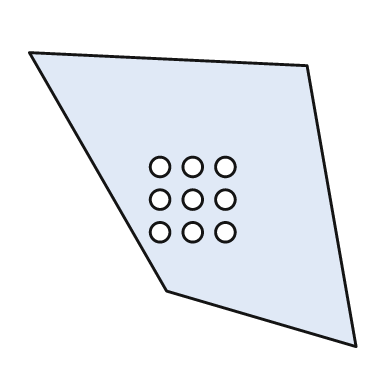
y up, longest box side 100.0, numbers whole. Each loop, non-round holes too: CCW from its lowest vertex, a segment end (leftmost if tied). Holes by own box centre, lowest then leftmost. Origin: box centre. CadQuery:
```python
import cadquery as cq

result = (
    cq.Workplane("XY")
    .moveTo(50.0, -45.0)
    .lineTo(35.0, 41.0)
    .lineTo(-50.0, 45.0)
    .lineTo(-8.0, -28.0)
    .close()
    .moveTo(-10.0, -10.0)
    .circle(3.0)
    .moveTo(0.0, -10.0)
    .circle(3.0)
    .moveTo(10.0, -10.0)
    .circle(3.0)
    .moveTo(-10.0, 0.0)
    .circle(3.0)
    .moveTo(0.0, 0.0)
    .circle(3.0)
    .moveTo(10.0, 0.0)
    .circle(3.0)
    .moveTo(-10.0, 10.0)
    .circle(3.0)
    .moveTo(0.0, 10.0)
    .circle(3.0)
    .moveTo(10.0, 10.0)
    .circle(3.0)
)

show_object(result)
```